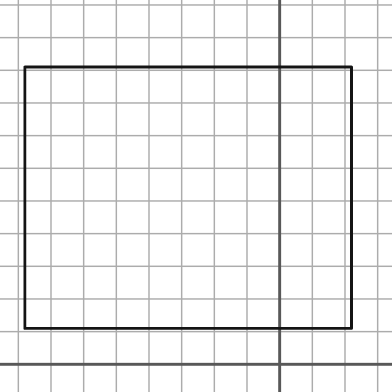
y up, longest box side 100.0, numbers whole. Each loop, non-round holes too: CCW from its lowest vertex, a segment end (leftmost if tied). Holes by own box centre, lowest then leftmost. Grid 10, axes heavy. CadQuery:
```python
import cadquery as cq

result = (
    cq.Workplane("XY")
    .moveTo(-78.0, 11.0)
    .lineTo(22.0, 11.0)
    .lineTo(22.0, 91.0)
    .lineTo(-78.0, 91.0)
    .close()
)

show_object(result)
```